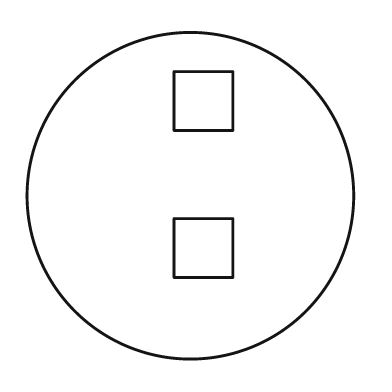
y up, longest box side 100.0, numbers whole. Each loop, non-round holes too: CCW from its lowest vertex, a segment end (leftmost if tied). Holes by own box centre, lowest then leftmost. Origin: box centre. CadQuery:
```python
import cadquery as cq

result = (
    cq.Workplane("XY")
    .moveTo(0.0, 0.0)
    .circle(50.0)
    .moveTo(-5.0, -25.0)
    .lineTo(13.0, -25.0)
    .lineTo(13.0, -7.0)
    .lineTo(-5.0, -7.0)
    .close()
    .moveTo(-5.0, 20.0)
    .lineTo(13.0, 20.0)
    .lineTo(13.0, 38.0)
    .lineTo(-5.0, 38.0)
    .close()
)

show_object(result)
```